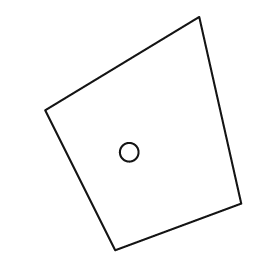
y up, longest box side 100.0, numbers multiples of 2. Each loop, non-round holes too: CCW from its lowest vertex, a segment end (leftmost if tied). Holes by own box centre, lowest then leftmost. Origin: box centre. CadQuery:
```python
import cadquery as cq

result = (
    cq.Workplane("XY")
    .moveTo(-12.0, -50.0)
    .lineTo(42.0, -30.0)
    .lineTo(24.0, 50.0)
    .lineTo(-42.0, 10.0)
    .close()
    .moveTo(-6.0, -8.0)
    .circle(4.0)
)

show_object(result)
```